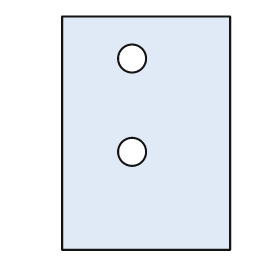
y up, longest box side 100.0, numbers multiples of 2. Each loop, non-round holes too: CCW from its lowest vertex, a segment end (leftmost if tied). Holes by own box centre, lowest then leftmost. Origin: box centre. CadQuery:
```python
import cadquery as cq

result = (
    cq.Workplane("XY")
    .moveTo(-36.0, -50.0)
    .lineTo(36.0, -50.0)
    .lineTo(36.0, 50.0)
    .lineTo(-36.0, 50.0)
    .close()
    .moveTo(-6.0, -8.0)
    .circle(6.0)
    .moveTo(-6.0, 32.0)
    .circle(6.0)
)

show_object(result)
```